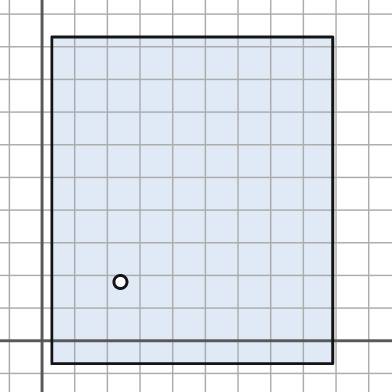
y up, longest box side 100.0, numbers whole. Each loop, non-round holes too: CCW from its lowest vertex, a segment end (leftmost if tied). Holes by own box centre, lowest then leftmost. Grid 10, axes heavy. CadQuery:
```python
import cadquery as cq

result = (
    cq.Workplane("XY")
    .moveTo(3.0, -7.0)
    .lineTo(89.0, -7.0)
    .lineTo(89.0, 93.0)
    .lineTo(3.0, 93.0)
    .close()
    .moveTo(24.0, 18.0)
    .circle(2.0)
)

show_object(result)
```